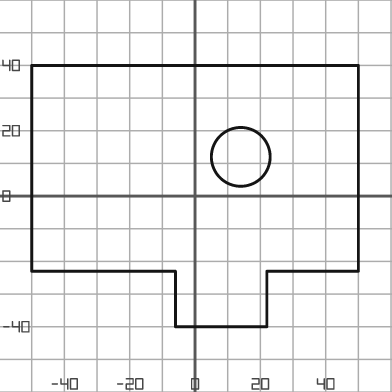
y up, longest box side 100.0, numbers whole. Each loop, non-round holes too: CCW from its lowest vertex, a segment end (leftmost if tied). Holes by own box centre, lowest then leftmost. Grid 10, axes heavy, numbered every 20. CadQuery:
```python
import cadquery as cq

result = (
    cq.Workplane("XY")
    .moveTo(-6.0, -40.0)
    .lineTo(22.0, -40.0)
    .lineTo(22.0, -23.0)
    .lineTo(50.0, -23.0)
    .lineTo(50.0, 40.0)
    .lineTo(-50.0, 40.0)
    .lineTo(-50.0, -23.0)
    .lineTo(-6.0, -23.0)
    .close()
    .moveTo(14.0, 12.0)
    .circle(9.0)
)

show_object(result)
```